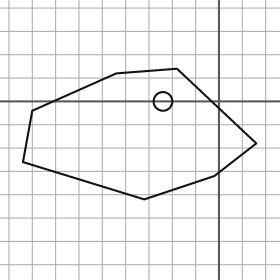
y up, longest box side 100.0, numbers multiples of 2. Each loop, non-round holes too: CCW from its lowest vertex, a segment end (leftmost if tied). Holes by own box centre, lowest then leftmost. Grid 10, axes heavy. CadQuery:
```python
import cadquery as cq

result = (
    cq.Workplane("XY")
    .moveTo(-32.0, -42.0)
    .lineTo(-2.0, -32.0)
    .lineTo(16.0, -18.0)
    .lineTo(-18.0, 14.0)
    .lineTo(-44.0, 12.0)
    .lineTo(-80.0, -4.0)
    .lineTo(-84.0, -26.0)
    .close()
    .moveTo(-24.0, 0.0)
    .circle(4.0)
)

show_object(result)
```